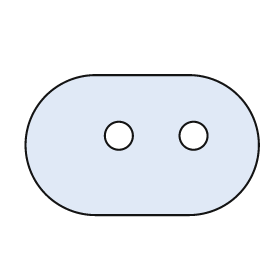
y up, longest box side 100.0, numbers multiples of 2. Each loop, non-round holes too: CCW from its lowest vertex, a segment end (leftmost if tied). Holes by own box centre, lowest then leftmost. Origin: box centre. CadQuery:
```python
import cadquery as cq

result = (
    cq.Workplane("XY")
    .moveTo(-20.0, -30.0)
    .lineTo(20.0, -30.0)
    .threePointArc((50.0, 0.0), (20.0, 30.0))
    .lineTo(-20.0, 30.0)
    .threePointArc((-50.0, 0.0), (-20.0, -30.0))
    .close()
    .moveTo(-10.0, 4.0)
    .circle(6.0)
    .moveTo(22.0, 4.0)
    .circle(6.0)
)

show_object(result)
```